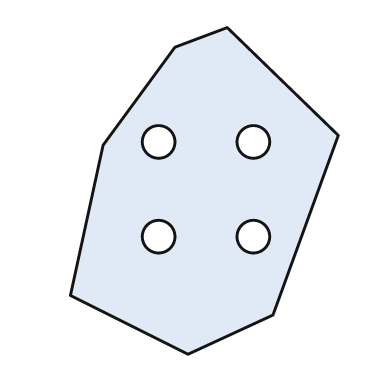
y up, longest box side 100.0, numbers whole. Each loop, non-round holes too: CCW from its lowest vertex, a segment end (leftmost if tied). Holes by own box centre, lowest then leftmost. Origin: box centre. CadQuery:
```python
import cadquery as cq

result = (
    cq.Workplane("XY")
    .moveTo(-5.0, -50.0)
    .lineTo(21.0, -38.0)
    .lineTo(41.0, 17.0)
    .lineTo(7.0, 50.0)
    .lineTo(-9.0, 44.0)
    .lineTo(-31.0, 14.0)
    .lineTo(-41.0, -32.0)
    .close()
    .moveTo(-14.0, -14.0)
    .circle(5.0)
    .moveTo(15.0, -14.0)
    .circle(5.0)
    .moveTo(-14.0, 15.0)
    .circle(5.0)
    .moveTo(15.0, 15.0)
    .circle(5.0)
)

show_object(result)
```